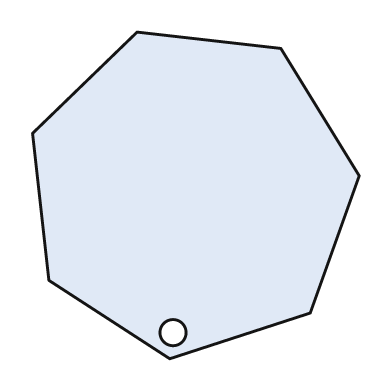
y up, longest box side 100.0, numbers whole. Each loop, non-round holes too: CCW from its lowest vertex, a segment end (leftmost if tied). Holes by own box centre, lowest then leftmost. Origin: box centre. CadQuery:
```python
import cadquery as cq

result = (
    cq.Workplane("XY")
    .moveTo(-8.0, -50.0)
    .lineTo(35.0, -36.0)
    .lineTo(50.0, 6.0)
    .lineTo(26.0, 45.0)
    .lineTo(-18.0, 50.0)
    .lineTo(-50.0, 19.0)
    .lineTo(-45.0, -26.0)
    .close()
    .moveTo(-7.0, -42.0)
    .circle(4.0)
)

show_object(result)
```